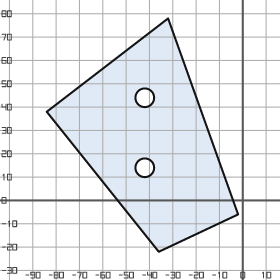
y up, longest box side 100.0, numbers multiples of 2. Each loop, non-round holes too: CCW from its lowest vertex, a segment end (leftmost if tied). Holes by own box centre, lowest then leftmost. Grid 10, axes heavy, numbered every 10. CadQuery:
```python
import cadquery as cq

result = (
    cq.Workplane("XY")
    .moveTo(-36.0, -22.0)
    .lineTo(-2.0, -6.0)
    .lineTo(-32.0, 78.0)
    .lineTo(-84.0, 38.0)
    .close()
    .moveTo(-42.0, 14.0)
    .circle(4.0)
    .moveTo(-42.0, 44.0)
    .circle(4.0)
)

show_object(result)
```